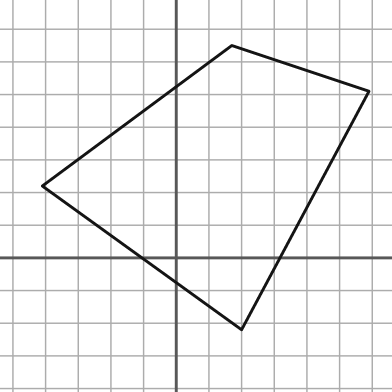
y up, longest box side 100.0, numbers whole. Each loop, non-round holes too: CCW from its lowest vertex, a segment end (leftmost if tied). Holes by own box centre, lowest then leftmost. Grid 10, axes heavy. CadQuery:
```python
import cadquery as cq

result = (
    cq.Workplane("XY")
    .moveTo(20.0, -22.0)
    .lineTo(59.0, 51.0)
    .lineTo(17.0, 65.0)
    .lineTo(-41.0, 22.0)
    .close()
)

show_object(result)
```